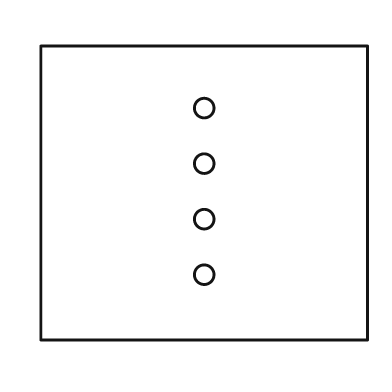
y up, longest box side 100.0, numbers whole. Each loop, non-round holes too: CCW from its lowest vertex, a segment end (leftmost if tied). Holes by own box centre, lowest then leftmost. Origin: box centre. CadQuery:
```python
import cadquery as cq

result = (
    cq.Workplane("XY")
    .moveTo(-50.0, -45.0)
    .lineTo(50.0, -45.0)
    .lineTo(50.0, 45.0)
    .lineTo(-50.0, 45.0)
    .close()
    .moveTo(0.0, -25.0)
    .circle(3.0)
    .moveTo(0.0, -8.0)
    .circle(3.0)
    .moveTo(0.0, 9.0)
    .circle(3.0)
    .moveTo(0.0, 26.0)
    .circle(3.0)
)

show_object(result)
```